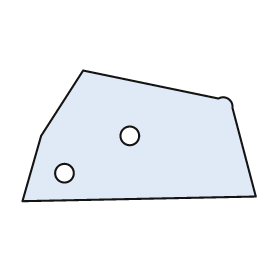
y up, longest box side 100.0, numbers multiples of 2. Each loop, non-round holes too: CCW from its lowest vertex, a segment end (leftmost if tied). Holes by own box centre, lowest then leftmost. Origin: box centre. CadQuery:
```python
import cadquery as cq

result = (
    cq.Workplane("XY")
    .moveTo(-50.0, -28.0)
    .lineTo(50.0, -26.0)
    .lineTo(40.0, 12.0)
    .threePointArc((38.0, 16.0), (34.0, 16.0))
    .lineTo(-24.0, 28.0)
    .lineTo(-42.0, 0.0)
    .close()
    .moveTo(-32.0, -16.0)
    .circle(4.0)
    .moveTo(-4.0, 0.0)
    .circle(4.0)
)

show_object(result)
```